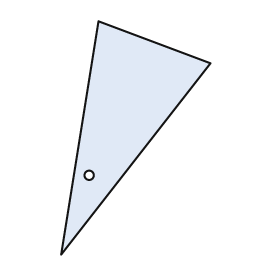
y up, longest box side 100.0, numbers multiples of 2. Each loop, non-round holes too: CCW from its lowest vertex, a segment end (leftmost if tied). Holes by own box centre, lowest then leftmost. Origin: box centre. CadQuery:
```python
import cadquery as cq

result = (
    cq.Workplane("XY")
    .moveTo(-32.0, -50.0)
    .lineTo(32.0, 32.0)
    .lineTo(-16.0, 50.0)
    .close()
    .moveTo(-20.0, -16.0)
    .circle(2.0)
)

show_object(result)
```